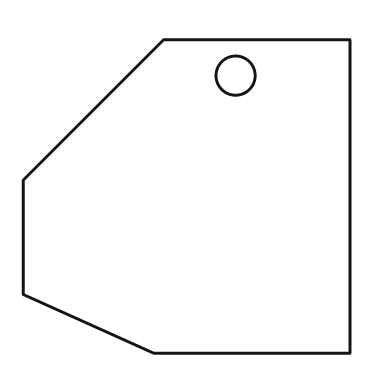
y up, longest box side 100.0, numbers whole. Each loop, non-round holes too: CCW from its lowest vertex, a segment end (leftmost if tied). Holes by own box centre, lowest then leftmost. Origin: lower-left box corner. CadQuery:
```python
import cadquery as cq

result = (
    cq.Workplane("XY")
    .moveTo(40.0, 0.0)
    .lineTo(100.0, 0.0)
    .lineTo(100.0, 96.0)
    .lineTo(43.0, 96.0)
    .lineTo(0.0, 53.0)
    .lineTo(0.0, 18.0)
    .close()
    .moveTo(65.0, 85.0)
    .circle(6.0)
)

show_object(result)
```